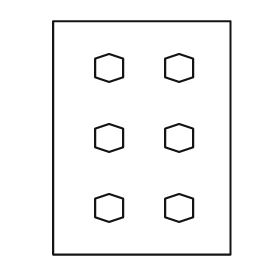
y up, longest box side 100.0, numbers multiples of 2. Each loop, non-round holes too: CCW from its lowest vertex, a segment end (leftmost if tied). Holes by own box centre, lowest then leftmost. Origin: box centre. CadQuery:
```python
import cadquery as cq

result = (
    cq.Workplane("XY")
    .moveTo(-38.0, -50.0)
    .lineTo(38.0, -50.0)
    .lineTo(38.0, 50.0)
    .lineTo(-38.0, 50.0)
    .close()
    .moveTo(-14.0, -36.0)
    .lineTo(-8.0, -34.0)
    .lineTo(-8.0, -26.0)
    .lineTo(-14.0, -24.0)
    .lineTo(-20.0, -26.0)
    .lineTo(-20.0, -34.0)
    .close()
    .moveTo(16.0, -36.0)
    .lineTo(22.0, -34.0)
    .lineTo(22.0, -26.0)
    .lineTo(16.0, -24.0)
    .lineTo(10.0, -26.0)
    .lineTo(10.0, -34.0)
    .close()
    .moveTo(-14.0, -6.0)
    .lineTo(-8.0, -4.0)
    .lineTo(-8.0, 4.0)
    .lineTo(-14.0, 6.0)
    .lineTo(-20.0, 4.0)
    .lineTo(-20.0, -4.0)
    .close()
    .moveTo(16.0, -6.0)
    .lineTo(22.0, -4.0)
    .lineTo(22.0, 4.0)
    .lineTo(16.0, 6.0)
    .lineTo(10.0, 4.0)
    .lineTo(10.0, -4.0)
    .close()
    .moveTo(-14.0, 24.0)
    .lineTo(-8.0, 26.0)
    .lineTo(-8.0, 34.0)
    .lineTo(-14.0, 36.0)
    .lineTo(-20.0, 34.0)
    .lineTo(-20.0, 26.0)
    .close()
    .moveTo(16.0, 24.0)
    .lineTo(22.0, 26.0)
    .lineTo(22.0, 34.0)
    .lineTo(16.0, 36.0)
    .lineTo(10.0, 34.0)
    .lineTo(10.0, 26.0)
    .close()
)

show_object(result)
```